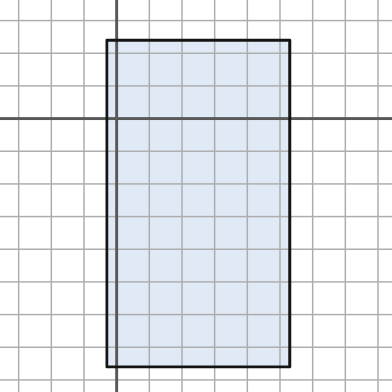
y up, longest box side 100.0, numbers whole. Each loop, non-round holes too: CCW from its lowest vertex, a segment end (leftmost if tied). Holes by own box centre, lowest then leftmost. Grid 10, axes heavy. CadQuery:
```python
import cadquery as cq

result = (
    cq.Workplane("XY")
    .moveTo(-3.0, -76.0)
    .lineTo(53.0, -76.0)
    .lineTo(53.0, 24.0)
    .lineTo(-3.0, 24.0)
    .close()
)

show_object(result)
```